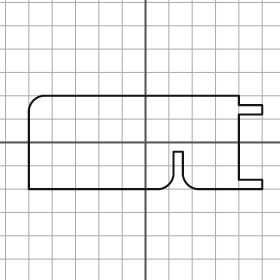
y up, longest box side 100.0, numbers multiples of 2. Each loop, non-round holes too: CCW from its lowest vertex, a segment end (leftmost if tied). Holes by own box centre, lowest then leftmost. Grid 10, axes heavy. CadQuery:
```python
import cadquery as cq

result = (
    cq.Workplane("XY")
    .moveTo(-50.0, -20.0)
    .lineTo(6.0, -20.0)
    .threePointArc((10.0, -18.0), (12.0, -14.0))
    .lineTo(12.0, -4.0)
    .lineTo(16.0, -4.0)
    .lineTo(16.0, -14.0)
    .threePointArc((18.0, -18.0), (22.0, -20.0))
    .lineTo(50.0, -20.0)
    .lineTo(50.0, -16.0)
    .lineTo(40.0, -16.0)
    .lineTo(40.0, 12.0)
    .lineTo(50.0, 12.0)
    .lineTo(50.0, 16.0)
    .lineTo(40.0, 16.0)
    .lineTo(40.0, 20.0)
    .lineTo(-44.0, 20.0)
    .threePointArc((-48.0, 18.0), (-50.0, 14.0))
    .close()
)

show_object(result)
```